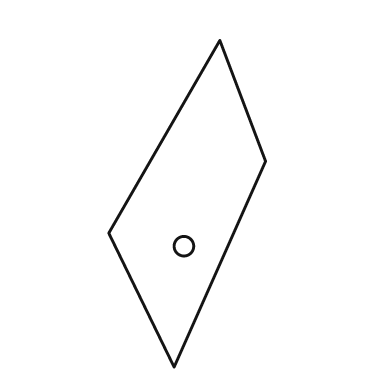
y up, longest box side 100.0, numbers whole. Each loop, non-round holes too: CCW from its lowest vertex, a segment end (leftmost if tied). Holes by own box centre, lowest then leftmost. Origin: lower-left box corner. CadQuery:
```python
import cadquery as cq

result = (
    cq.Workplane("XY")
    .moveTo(20.0, 0.0)
    .lineTo(48.0, 63.0)
    .lineTo(34.0, 100.0)
    .lineTo(0.0, 41.0)
    .close()
    .moveTo(23.0, 37.0)
    .circle(3.0)
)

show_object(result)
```